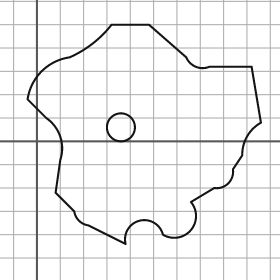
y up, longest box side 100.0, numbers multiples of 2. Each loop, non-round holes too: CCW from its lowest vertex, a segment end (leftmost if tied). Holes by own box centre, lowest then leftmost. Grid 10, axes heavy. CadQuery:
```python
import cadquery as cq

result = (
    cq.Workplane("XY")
    .moveTo(38.0, -44.0)
    .threePointArc((44.0, -34.0), (54.0, -40.0))
    .threePointArc((66.0, -38.0), (66.0, -26.0))
    .lineTo(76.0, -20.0)
    .threePointArc((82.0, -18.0), (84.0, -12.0))
    .lineTo(88.0, -6.0)
    .threePointArc((90.0, 2.0), (96.0, 8.0))
    .lineTo(92.0, 32.0)
    .lineTo(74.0, 32.0)
    .threePointArc((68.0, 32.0), (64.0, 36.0))
    .lineTo(48.0, 50.0)
    .lineTo(32.0, 50.0)
    .threePointArc((24.0, 42.0), (14.0, 36.0))
    .threePointArc((2.0, 30.0), (-4.0, 18.0))
    .lineTo(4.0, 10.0)
    .threePointArc((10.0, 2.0), (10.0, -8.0))
    .lineTo(8.0, -22.0)
    .lineTo(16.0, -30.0)
    .threePointArc((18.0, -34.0), (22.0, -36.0))
    .close()
    .moveTo(36.0, 6.0)
    .circle(6.0)
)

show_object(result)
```